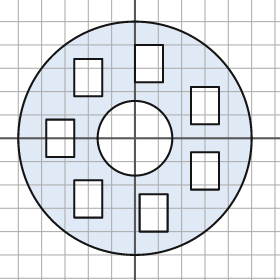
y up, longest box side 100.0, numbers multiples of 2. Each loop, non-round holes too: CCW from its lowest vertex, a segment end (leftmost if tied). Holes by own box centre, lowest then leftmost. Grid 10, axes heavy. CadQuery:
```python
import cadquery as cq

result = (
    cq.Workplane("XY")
    .moveTo(0.0, 0.0)
    .circle(50.0)
    .moveTo(2.0, -40.0)
    .lineTo(14.0, -40.0)
    .lineTo(14.0, -24.0)
    .lineTo(2.0, -24.0)
    .close()
    .moveTo(-26.0, -34.0)
    .lineTo(-14.0, -34.0)
    .lineTo(-14.0, -18.0)
    .lineTo(-26.0, -18.0)
    .close()
    .moveTo(24.0, -22.0)
    .lineTo(36.0, -22.0)
    .lineTo(36.0, -6.0)
    .lineTo(24.0, -6.0)
    .close()
    .moveTo(-38.0, -8.0)
    .lineTo(-26.0, -8.0)
    .lineTo(-26.0, 8.0)
    .lineTo(-38.0, 8.0)
    .close()
    .moveTo(0.0, 0.0)
    .circle(16.0)
    .moveTo(24.0, 6.0)
    .lineTo(36.0, 6.0)
    .lineTo(36.0, 22.0)
    .lineTo(24.0, 22.0)
    .close()
    .moveTo(-26.0, 18.0)
    .lineTo(-14.0, 18.0)
    .lineTo(-14.0, 34.0)
    .lineTo(-26.0, 34.0)
    .close()
    .moveTo(0.0, 24.0)
    .lineTo(12.0, 24.0)
    .lineTo(12.0, 40.0)
    .lineTo(0.0, 40.0)
    .close()
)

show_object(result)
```